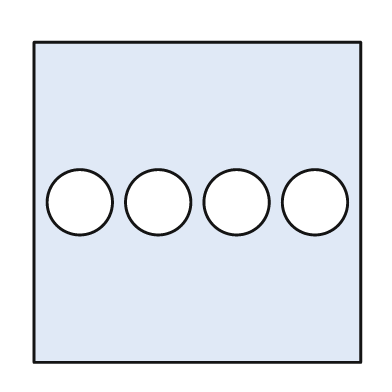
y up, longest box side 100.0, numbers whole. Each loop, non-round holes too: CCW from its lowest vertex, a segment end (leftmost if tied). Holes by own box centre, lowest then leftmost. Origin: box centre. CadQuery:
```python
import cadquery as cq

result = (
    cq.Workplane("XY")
    .moveTo(-50.0, -49.0)
    .lineTo(50.0, -49.0)
    .lineTo(50.0, 49.0)
    .lineTo(-50.0, 49.0)
    .close()
    .moveTo(-36.0, 0.0)
    .circle(10.0)
    .moveTo(-12.0, 0.0)
    .circle(10.0)
    .moveTo(12.0, 0.0)
    .circle(10.0)
    .moveTo(36.0, 0.0)
    .circle(10.0)
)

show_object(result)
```